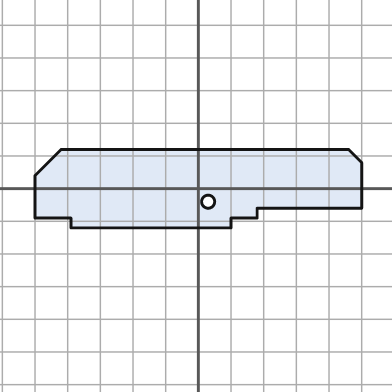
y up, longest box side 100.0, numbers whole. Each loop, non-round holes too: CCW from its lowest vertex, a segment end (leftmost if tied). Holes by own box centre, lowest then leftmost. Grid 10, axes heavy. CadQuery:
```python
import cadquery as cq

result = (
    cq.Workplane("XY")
    .moveTo(-39.0, -12.0)
    .lineTo(10.0, -12.0)
    .lineTo(10.0, -9.0)
    .lineTo(18.0, -9.0)
    .lineTo(18.0, -6.0)
    .lineTo(50.0, -6.0)
    .lineTo(50.0, 8.0)
    .lineTo(46.0, 12.0)
    .lineTo(-42.0, 12.0)
    .lineTo(-50.0, 4.0)
    .lineTo(-50.0, -9.0)
    .lineTo(-39.0, -9.0)
    .close()
    .moveTo(3.0, -4.0)
    .circle(2.0)
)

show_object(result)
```